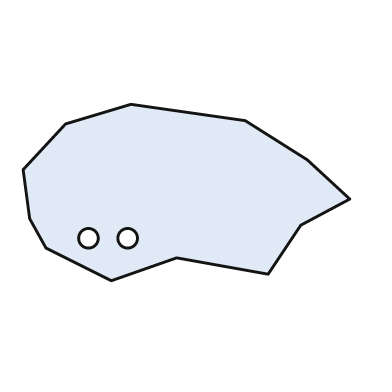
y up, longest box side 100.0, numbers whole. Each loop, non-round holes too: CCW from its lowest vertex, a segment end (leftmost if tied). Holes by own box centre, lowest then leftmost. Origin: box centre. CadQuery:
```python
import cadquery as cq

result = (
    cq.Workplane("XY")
    .moveTo(-23.0, -27.0)
    .lineTo(-3.0, -20.0)
    .lineTo(25.0, -25.0)
    .lineTo(35.0, -10.0)
    .lineTo(50.0, -2.0)
    .lineTo(37.0, 10.0)
    .lineTo(18.0, 22.0)
    .lineTo(-17.0, 27.0)
    .lineTo(-37.0, 21.0)
    .lineTo(-50.0, 7.0)
    .lineTo(-48.0, -8.0)
    .lineTo(-43.0, -17.0)
    .close()
    .moveTo(-30.0, -14.0)
    .circle(3.0)
    .moveTo(-18.0, -14.0)
    .circle(3.0)
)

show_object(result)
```